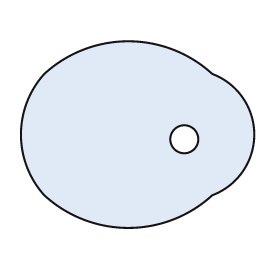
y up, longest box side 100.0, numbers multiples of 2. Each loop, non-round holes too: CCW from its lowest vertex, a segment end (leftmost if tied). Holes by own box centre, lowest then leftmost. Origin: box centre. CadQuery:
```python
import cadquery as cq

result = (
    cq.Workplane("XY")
    .moveTo(-40.0, -26.0)
    .threePointArc((-4.0, -40.0), (32.0, -26.0))
    .threePointArc((50.0, 0.0), (32.0, 26.0))
    .threePointArc((-4.0, 40.0), (-40.0, 26.0))
    .threePointArc((-50.0, 0.0), (-40.0, -26.0))
    .close()
    .moveTo(20.0, -2.0)
    .circle(6.0)
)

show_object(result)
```